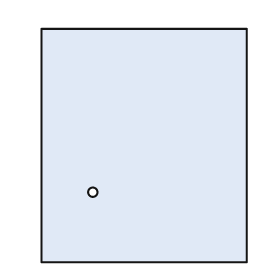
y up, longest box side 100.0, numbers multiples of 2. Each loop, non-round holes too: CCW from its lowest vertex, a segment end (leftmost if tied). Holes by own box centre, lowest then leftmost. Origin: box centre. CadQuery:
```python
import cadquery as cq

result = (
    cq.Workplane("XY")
    .moveTo(-44.0, -50.0)
    .lineTo(44.0, -50.0)
    .lineTo(44.0, 50.0)
    .lineTo(-44.0, 50.0)
    .close()
    .moveTo(-22.0, -20.0)
    .circle(2.0)
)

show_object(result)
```